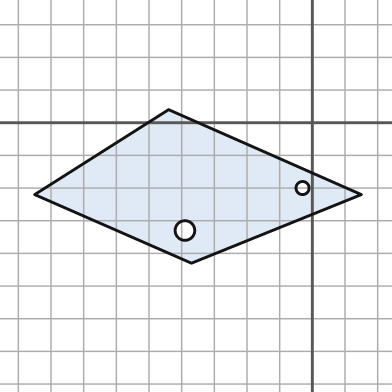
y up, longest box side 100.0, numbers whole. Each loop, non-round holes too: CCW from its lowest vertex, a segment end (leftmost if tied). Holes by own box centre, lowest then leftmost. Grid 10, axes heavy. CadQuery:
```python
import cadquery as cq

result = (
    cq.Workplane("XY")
    .moveTo(-37.0, -43.0)
    .lineTo(15.0, -22.0)
    .lineTo(-44.0, 4.0)
    .lineTo(-85.0, -22.0)
    .close()
    .moveTo(-39.0, -33.0)
    .circle(3.0)
    .moveTo(-3.0, -20.0)
    .circle(2.0)
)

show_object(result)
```